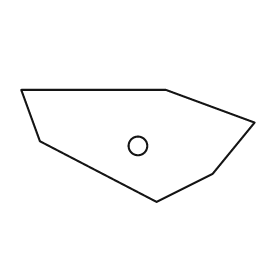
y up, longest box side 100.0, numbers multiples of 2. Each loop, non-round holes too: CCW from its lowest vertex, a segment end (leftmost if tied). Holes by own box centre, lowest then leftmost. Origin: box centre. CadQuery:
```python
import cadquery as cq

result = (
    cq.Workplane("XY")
    .moveTo(8.0, -24.0)
    .lineTo(32.0, -12.0)
    .lineTo(50.0, 10.0)
    .lineTo(12.0, 24.0)
    .lineTo(-50.0, 24.0)
    .lineTo(-42.0, 2.0)
    .close()
    .moveTo(0.0, 0.0)
    .circle(4.0)
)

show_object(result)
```